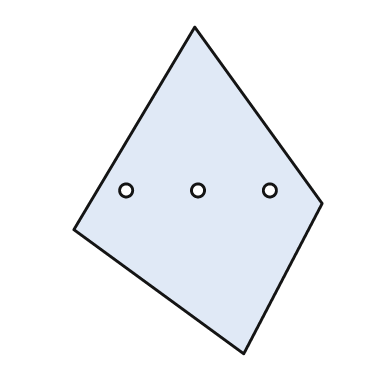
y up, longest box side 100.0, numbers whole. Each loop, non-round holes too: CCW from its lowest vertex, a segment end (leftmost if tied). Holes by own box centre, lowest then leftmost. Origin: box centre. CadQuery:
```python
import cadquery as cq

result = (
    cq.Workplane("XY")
    .moveTo(14.0, -50.0)
    .lineTo(38.0, -4.0)
    .lineTo(-1.0, 50.0)
    .lineTo(-38.0, -12.0)
    .close()
    .moveTo(-22.0, 0.0)
    .circle(2.0)
    .moveTo(0.0, 0.0)
    .circle(2.0)
    .moveTo(22.0, 0.0)
    .circle(2.0)
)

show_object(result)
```